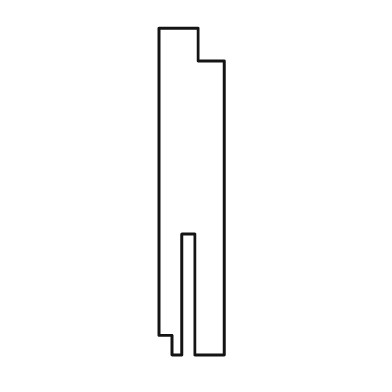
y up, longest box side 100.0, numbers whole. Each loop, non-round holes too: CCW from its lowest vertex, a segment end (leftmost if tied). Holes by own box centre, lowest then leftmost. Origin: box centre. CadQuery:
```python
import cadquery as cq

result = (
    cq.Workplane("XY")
    .moveTo(-6.0, -50.0)
    .lineTo(-3.0, -50.0)
    .lineTo(-3.0, -13.0)
    .lineTo(1.0, -13.0)
    .lineTo(1.0, -50.0)
    .lineTo(10.0, -50.0)
    .lineTo(10.0, 40.0)
    .lineTo(2.0, 40.0)
    .lineTo(2.0, 50.0)
    .lineTo(-10.0, 50.0)
    .lineTo(-10.0, -44.0)
    .lineTo(-6.0, -44.0)
    .close()
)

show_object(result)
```